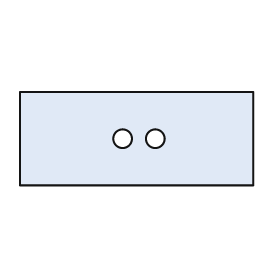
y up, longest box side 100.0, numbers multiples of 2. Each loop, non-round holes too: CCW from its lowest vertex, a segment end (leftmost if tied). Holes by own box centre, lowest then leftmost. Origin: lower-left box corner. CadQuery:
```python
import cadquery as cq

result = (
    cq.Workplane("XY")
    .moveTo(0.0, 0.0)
    .lineTo(100.0, 0.0)
    .lineTo(100.0, 40.0)
    .lineTo(0.0, 40.0)
    .close()
    .moveTo(44.0, 20.0)
    .circle(4.0)
    .moveTo(58.0, 20.0)
    .circle(4.0)
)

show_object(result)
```